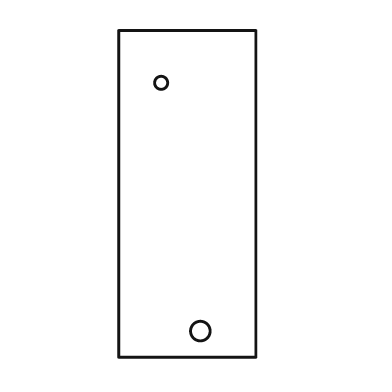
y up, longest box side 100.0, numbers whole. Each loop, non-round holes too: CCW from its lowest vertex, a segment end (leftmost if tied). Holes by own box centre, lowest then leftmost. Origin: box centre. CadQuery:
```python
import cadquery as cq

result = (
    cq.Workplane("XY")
    .moveTo(-21.0, -50.0)
    .lineTo(21.0, -50.0)
    .lineTo(21.0, 50.0)
    .lineTo(-21.0, 50.0)
    .close()
    .moveTo(4.0, -42.0)
    .circle(3.0)
    .moveTo(-8.0, 34.0)
    .circle(2.0)
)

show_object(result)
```